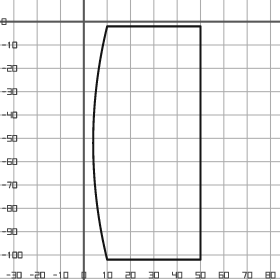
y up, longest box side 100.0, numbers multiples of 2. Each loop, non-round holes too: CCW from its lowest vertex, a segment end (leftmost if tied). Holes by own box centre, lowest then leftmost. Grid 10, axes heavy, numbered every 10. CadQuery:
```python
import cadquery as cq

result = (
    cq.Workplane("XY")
    .moveTo(10.0, -102.0)
    .lineTo(50.0, -102.0)
    .lineTo(50.0, -2.0)
    .lineTo(10.0, -2.0)
    .threePointArc((4.0, -52.0), (10.0, -102.0))
    .close()
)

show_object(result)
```